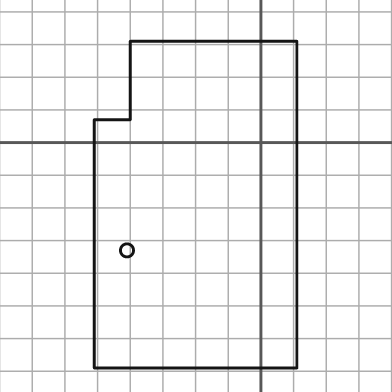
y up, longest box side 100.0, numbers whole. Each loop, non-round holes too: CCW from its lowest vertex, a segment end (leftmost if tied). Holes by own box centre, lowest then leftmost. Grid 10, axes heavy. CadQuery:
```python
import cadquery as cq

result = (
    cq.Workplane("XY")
    .moveTo(-51.0, -69.0)
    .lineTo(11.0, -69.0)
    .lineTo(11.0, 31.0)
    .lineTo(-40.0, 31.0)
    .lineTo(-40.0, 7.0)
    .lineTo(-51.0, 7.0)
    .close()
    .moveTo(-41.0, -33.0)
    .circle(2.0)
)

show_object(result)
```